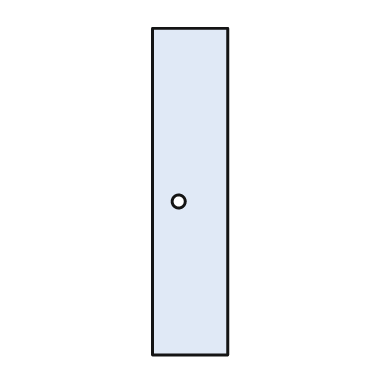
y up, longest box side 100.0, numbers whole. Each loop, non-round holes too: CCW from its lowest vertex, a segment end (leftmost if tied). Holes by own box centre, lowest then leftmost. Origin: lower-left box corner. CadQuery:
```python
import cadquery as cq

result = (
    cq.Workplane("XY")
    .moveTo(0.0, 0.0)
    .lineTo(23.0, 0.0)
    .lineTo(23.0, 100.0)
    .lineTo(0.0, 100.0)
    .close()
    .moveTo(8.0, 47.0)
    .circle(2.0)
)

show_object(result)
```